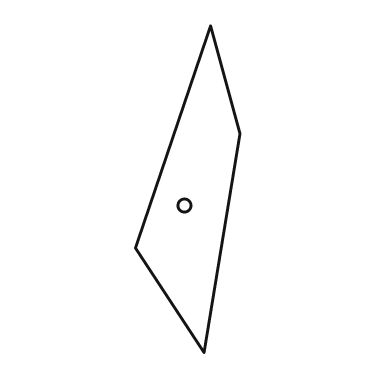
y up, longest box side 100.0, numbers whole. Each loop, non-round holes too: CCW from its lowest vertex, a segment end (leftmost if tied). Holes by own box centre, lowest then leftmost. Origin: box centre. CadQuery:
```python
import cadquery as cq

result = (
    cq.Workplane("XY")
    .moveTo(5.0, -50.0)
    .lineTo(16.0, 17.0)
    .lineTo(7.0, 50.0)
    .lineTo(-16.0, -18.0)
    .close()
    .moveTo(-1.0, -5.0)
    .circle(2.0)
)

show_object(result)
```